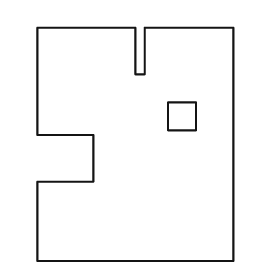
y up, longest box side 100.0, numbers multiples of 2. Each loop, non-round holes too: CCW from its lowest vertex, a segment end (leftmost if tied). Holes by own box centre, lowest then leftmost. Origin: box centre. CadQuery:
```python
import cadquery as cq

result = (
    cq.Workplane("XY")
    .moveTo(-42.0, -50.0)
    .lineTo(42.0, -50.0)
    .lineTo(42.0, 50.0)
    .lineTo(4.0, 50.0)
    .lineTo(4.0, 30.0)
    .lineTo(0.0, 30.0)
    .lineTo(0.0, 50.0)
    .lineTo(-42.0, 50.0)
    .lineTo(-42.0, 4.0)
    .lineTo(-18.0, 4.0)
    .lineTo(-18.0, -16.0)
    .lineTo(-42.0, -16.0)
    .close()
    .moveTo(14.0, 6.0)
    .lineTo(26.0, 6.0)
    .lineTo(26.0, 18.0)
    .lineTo(14.0, 18.0)
    .close()
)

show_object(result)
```